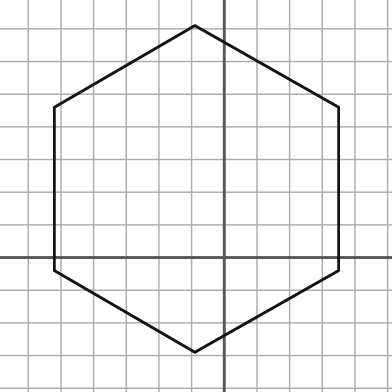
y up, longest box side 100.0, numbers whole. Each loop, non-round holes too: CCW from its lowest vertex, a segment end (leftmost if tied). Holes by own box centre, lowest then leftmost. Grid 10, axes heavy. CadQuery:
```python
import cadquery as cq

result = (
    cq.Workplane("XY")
    .moveTo(-9.0, -29.0)
    .lineTo(35.0, -4.0)
    .lineTo(35.0, 46.0)
    .lineTo(-9.0, 71.0)
    .lineTo(-52.0, 46.0)
    .lineTo(-52.0, -4.0)
    .close()
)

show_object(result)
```